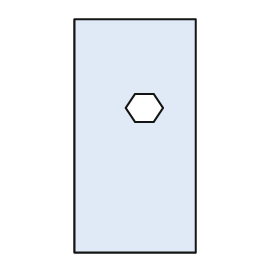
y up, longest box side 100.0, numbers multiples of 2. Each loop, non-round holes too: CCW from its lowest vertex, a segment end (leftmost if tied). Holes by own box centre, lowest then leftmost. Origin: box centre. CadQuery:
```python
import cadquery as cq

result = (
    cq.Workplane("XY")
    .moveTo(-26.0, -50.0)
    .lineTo(26.0, -50.0)
    .lineTo(26.0, 50.0)
    .lineTo(-26.0, 50.0)
    .close()
    .moveTo(0.0, 6.0)
    .lineTo(8.0, 6.0)
    .lineTo(12.0, 12.0)
    .lineTo(8.0, 18.0)
    .lineTo(0.0, 18.0)
    .lineTo(-4.0, 12.0)
    .close()
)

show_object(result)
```